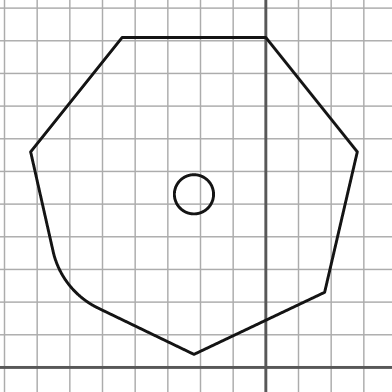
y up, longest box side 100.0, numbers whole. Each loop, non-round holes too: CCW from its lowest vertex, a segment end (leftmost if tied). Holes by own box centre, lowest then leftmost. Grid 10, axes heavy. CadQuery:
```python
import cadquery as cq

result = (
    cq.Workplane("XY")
    .moveTo(-22.0, 4.0)
    .lineTo(18.0, 23.0)
    .lineTo(28.0, 66.0)
    .lineTo(0.0, 101.0)
    .lineTo(-44.0, 101.0)
    .lineTo(-72.0, 66.0)
    .lineTo(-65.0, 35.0)
    .threePointArc((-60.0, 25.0), (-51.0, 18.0))
    .close()
    .moveTo(-22.0, 53.0)
    .circle(6.0)
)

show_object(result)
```